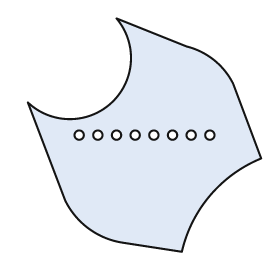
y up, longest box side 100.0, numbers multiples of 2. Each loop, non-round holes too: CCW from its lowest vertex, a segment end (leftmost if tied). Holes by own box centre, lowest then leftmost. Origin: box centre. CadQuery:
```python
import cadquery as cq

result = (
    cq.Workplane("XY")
    .moveTo(16.0, -50.0)
    .threePointArc((28.0, -26.0), (50.0, -10.0))
    .lineTo(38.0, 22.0)
    .threePointArc((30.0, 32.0), (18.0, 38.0))
    .lineTo(-12.0, 50.0)
    .threePointArc((-14.0, 14.0), (-50.0, 14.0))
    .lineTo(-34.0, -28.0)
    .threePointArc((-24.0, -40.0), (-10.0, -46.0))
    .close()
    .moveTo(-28.0, 0.0)
    .circle(2.0)
    .moveTo(-20.0, 0.0)
    .circle(2.0)
    .moveTo(-12.0, 0.0)
    .circle(2.0)
    .moveTo(-4.0, 0.0)
    .circle(2.0)
    .moveTo(4.0, 0.0)
    .circle(2.0)
    .moveTo(12.0, 0.0)
    .circle(2.0)
    .moveTo(20.0, 0.0)
    .circle(2.0)
    .moveTo(28.0, 0.0)
    .circle(2.0)
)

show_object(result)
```